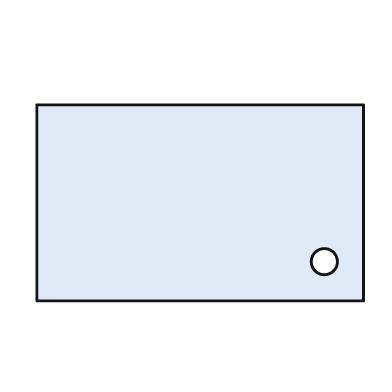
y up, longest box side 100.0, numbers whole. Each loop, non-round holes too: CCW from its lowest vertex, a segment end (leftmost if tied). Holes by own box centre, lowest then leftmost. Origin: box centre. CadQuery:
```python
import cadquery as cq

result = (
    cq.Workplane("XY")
    .moveTo(-50.0, -30.0)
    .lineTo(50.0, -30.0)
    .lineTo(50.0, 30.0)
    .lineTo(-50.0, 30.0)
    .close()
    .moveTo(38.0, -18.0)
    .circle(4.0)
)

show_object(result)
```